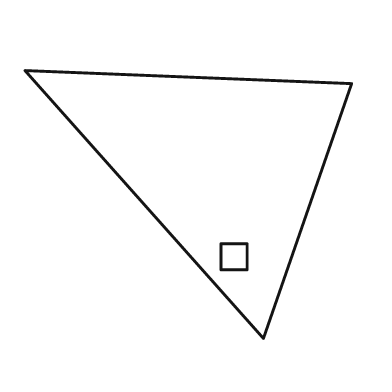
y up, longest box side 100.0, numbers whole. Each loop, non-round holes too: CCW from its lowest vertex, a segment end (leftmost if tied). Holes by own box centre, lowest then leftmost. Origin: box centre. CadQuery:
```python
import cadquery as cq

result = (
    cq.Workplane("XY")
    .moveTo(23.0, -41.0)
    .lineTo(50.0, 37.0)
    .lineTo(-50.0, 41.0)
    .close()
    .moveTo(10.0, -20.0)
    .lineTo(18.0, -20.0)
    .lineTo(18.0, -12.0)
    .lineTo(10.0, -12.0)
    .close()
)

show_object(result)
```